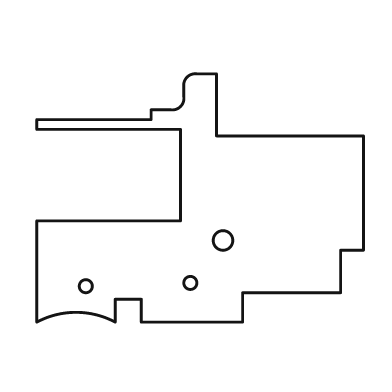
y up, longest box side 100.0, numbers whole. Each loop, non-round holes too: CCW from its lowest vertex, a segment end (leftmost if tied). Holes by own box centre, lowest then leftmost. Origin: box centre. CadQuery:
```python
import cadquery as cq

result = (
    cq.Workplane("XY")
    .moveTo(-50.0, -38.0)
    .threePointArc((-38.0, -35.0), (-26.0, -38.0))
    .lineTo(-26.0, -31.0)
    .lineTo(-18.0, -31.0)
    .lineTo(-18.0, -38.0)
    .lineTo(13.0, -38.0)
    .lineTo(13.0, -29.0)
    .lineTo(43.0, -29.0)
    .lineTo(43.0, -16.0)
    .lineTo(50.0, -16.0)
    .lineTo(50.0, 19.0)
    .lineTo(5.0, 19.0)
    .lineTo(5.0, 38.0)
    .lineTo(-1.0, 38.0)
    .threePointArc((-4.0, 37.0), (-5.0, 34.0))
    .lineTo(-5.0, 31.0)
    .threePointArc((-6.0, 28.0), (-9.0, 27.0))
    .lineTo(-15.0, 27.0)
    .lineTo(-15.0, 24.0)
    .lineTo(-50.0, 24.0)
    .lineTo(-50.0, 21.0)
    .lineTo(-6.0, 21.0)
    .lineTo(-6.0, -7.0)
    .lineTo(-50.0, -7.0)
    .close()
    .moveTo(-35.0, -27.0)
    .circle(2.0)
    .moveTo(-3.0, -26.0)
    .circle(2.0)
    .moveTo(7.0, -13.0)
    .circle(3.0)
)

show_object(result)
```